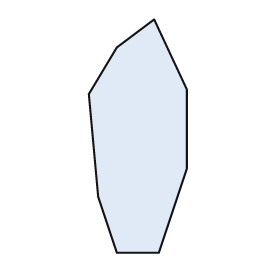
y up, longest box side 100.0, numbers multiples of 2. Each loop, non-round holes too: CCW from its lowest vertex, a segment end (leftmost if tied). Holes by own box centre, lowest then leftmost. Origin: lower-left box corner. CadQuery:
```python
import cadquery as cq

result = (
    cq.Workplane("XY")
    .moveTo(12.0, 0.0)
    .lineTo(30.0, 0.0)
    .lineTo(42.0, 36.0)
    .lineTo(42.0, 70.0)
    .lineTo(28.0, 100.0)
    .lineTo(12.0, 88.0)
    .lineTo(0.0, 68.0)
    .lineTo(4.0, 24.0)
    .close()
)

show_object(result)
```